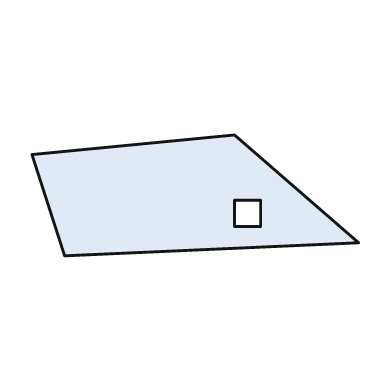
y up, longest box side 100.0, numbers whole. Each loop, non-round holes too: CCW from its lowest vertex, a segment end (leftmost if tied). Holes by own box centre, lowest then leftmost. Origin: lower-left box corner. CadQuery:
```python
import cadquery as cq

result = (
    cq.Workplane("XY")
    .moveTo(10.0, 0.0)
    .lineTo(100.0, 4.0)
    .lineTo(62.0, 37.0)
    .lineTo(0.0, 31.0)
    .close()
    .moveTo(62.0, 9.0)
    .lineTo(70.0, 9.0)
    .lineTo(70.0, 17.0)
    .lineTo(62.0, 17.0)
    .close()
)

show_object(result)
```